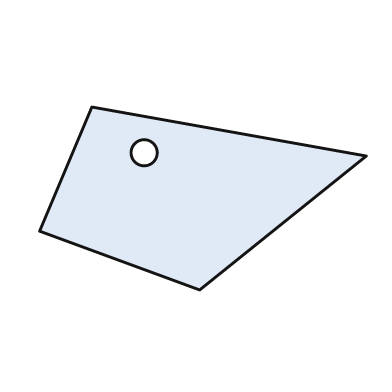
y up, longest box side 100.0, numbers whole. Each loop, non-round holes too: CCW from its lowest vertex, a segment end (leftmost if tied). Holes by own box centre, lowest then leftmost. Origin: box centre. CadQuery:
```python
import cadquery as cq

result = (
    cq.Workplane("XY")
    .moveTo(-1.0, -28.0)
    .lineTo(50.0, 13.0)
    .lineTo(-34.0, 28.0)
    .lineTo(-50.0, -10.0)
    .close()
    .moveTo(-18.0, 14.0)
    .circle(4.0)
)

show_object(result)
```